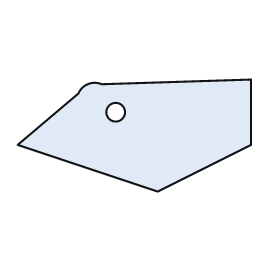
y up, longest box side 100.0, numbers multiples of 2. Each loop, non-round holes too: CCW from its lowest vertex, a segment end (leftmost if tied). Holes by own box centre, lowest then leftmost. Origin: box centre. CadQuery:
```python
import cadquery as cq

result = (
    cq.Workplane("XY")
    .moveTo(10.0, -24.0)
    .lineTo(50.0, -4.0)
    .lineTo(50.0, 24.0)
    .lineTo(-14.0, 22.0)
    .threePointArc((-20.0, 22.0), (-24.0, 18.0))
    .lineTo(-50.0, -4.0)
    .close()
    .moveTo(-8.0, 10.0)
    .circle(4.0)
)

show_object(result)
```